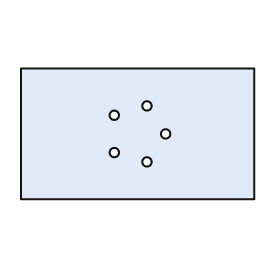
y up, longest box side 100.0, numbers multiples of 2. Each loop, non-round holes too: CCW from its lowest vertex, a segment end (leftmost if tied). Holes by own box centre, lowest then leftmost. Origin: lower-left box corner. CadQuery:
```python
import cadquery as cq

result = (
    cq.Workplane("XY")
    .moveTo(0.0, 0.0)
    .lineTo(100.0, 0.0)
    .lineTo(100.0, 56.0)
    .lineTo(0.0, 56.0)
    .close()
    .moveTo(54.0, 16.0)
    .circle(2.0)
    .moveTo(40.0, 20.0)
    .circle(2.0)
    .moveTo(62.0, 28.0)
    .circle(2.0)
    .moveTo(40.0, 36.0)
    .circle(2.0)
    .moveTo(54.0, 40.0)
    .circle(2.0)
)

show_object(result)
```